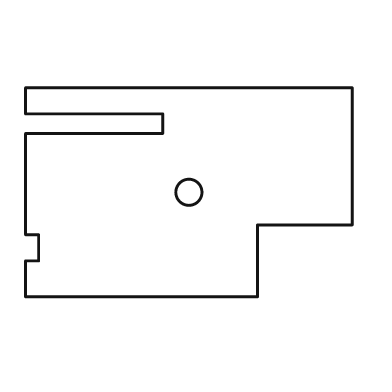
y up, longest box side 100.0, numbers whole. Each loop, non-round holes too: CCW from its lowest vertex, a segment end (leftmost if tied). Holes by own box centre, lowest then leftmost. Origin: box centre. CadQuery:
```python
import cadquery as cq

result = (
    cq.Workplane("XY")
    .moveTo(-50.0, -32.0)
    .lineTo(21.0, -32.0)
    .lineTo(21.0, -10.0)
    .lineTo(50.0, -10.0)
    .lineTo(50.0, 32.0)
    .lineTo(-50.0, 32.0)
    .lineTo(-50.0, 24.0)
    .lineTo(-8.0, 24.0)
    .lineTo(-8.0, 18.0)
    .lineTo(-50.0, 18.0)
    .lineTo(-50.0, -13.0)
    .lineTo(-46.0, -13.0)
    .lineTo(-46.0, -21.0)
    .lineTo(-50.0, -21.0)
    .close()
    .moveTo(0.0, 0.0)
    .circle(4.0)
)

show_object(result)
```